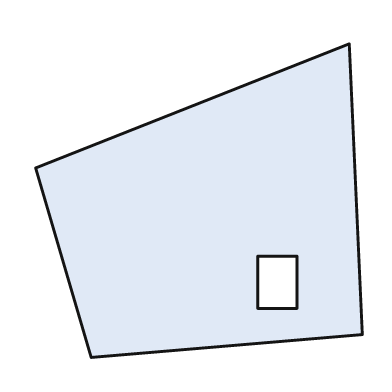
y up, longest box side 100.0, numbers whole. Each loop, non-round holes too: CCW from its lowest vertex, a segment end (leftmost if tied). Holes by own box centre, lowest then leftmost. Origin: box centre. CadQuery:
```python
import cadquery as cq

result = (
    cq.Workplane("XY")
    .moveTo(-33.0, -48.0)
    .lineTo(50.0, -41.0)
    .lineTo(46.0, 48.0)
    .lineTo(-50.0, 10.0)
    .close()
    .moveTo(18.0, -33.0)
    .lineTo(30.0, -33.0)
    .lineTo(30.0, -17.0)
    .lineTo(18.0, -17.0)
    .close()
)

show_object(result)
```